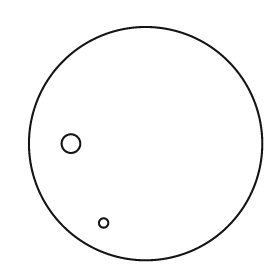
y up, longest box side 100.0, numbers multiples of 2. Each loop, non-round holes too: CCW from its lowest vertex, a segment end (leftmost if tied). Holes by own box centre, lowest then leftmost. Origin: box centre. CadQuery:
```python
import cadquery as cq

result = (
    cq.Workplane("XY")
    .moveTo(0.0, 0.0)
    .circle(50.0)
    .moveTo(-18.0, -34.0)
    .circle(2.0)
    .moveTo(-32.0, 0.0)
    .circle(4.0)
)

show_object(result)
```